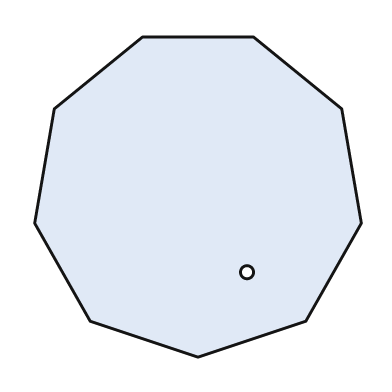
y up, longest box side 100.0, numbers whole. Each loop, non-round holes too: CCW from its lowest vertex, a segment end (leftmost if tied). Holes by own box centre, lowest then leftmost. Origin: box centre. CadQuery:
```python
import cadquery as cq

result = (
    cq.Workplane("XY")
    .moveTo(0.0, -49.0)
    .lineTo(33.0, -38.0)
    .lineTo(50.0, -8.0)
    .lineTo(44.0, 27.0)
    .lineTo(17.0, 49.0)
    .lineTo(-17.0, 49.0)
    .lineTo(-44.0, 27.0)
    .lineTo(-50.0, -8.0)
    .lineTo(-33.0, -38.0)
    .close()
    .moveTo(15.0, -23.0)
    .circle(2.0)
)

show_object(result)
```